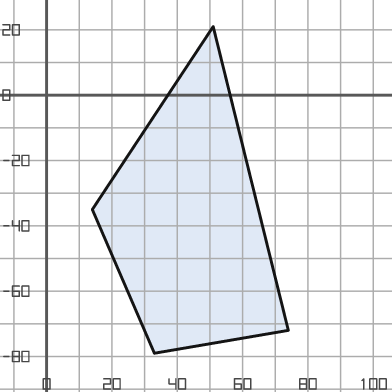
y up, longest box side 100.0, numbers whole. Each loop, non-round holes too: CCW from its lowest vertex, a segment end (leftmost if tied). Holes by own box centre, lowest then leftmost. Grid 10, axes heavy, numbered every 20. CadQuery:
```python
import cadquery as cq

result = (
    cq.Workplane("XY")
    .moveTo(33.0, -79.0)
    .lineTo(74.0, -72.0)
    .lineTo(51.0, 21.0)
    .lineTo(14.0, -35.0)
    .close()
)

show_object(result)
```